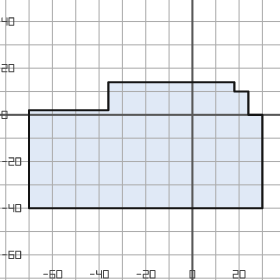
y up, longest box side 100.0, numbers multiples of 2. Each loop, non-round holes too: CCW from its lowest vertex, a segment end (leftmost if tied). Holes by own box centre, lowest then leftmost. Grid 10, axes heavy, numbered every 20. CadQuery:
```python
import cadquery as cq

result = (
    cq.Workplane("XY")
    .moveTo(-70.0, -40.0)
    .lineTo(30.0, -40.0)
    .lineTo(30.0, 0.0)
    .lineTo(24.0, 0.0)
    .lineTo(24.0, 10.0)
    .lineTo(18.0, 10.0)
    .lineTo(18.0, 14.0)
    .lineTo(-36.0, 14.0)
    .lineTo(-36.0, 2.0)
    .lineTo(-70.0, 2.0)
    .close()
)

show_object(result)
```